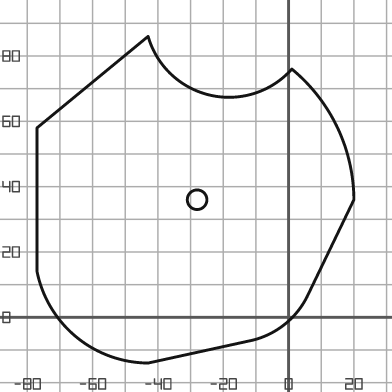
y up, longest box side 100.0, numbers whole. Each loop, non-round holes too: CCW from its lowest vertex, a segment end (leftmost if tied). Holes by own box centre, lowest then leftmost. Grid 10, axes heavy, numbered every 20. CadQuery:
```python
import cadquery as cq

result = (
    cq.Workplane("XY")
    .moveTo(-43.0, -14.0)
    .lineTo(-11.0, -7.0)
    .threePointArc((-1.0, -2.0), (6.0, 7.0))
    .lineTo(20.0, 36.0)
    .threePointArc((15.0, 58.0), (1.0, 76.0))
    .threePointArc((-24.0, 68.0), (-43.0, 86.0))
    .lineTo(-77.0, 58.0)
    .lineTo(-77.0, 14.0)
    .threePointArc((-65.0, -6.0), (-43.0, -14.0))
    .close()
    .moveTo(-28.0, 36.0)
    .circle(3.0)
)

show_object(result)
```